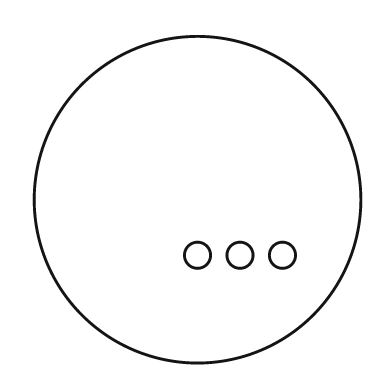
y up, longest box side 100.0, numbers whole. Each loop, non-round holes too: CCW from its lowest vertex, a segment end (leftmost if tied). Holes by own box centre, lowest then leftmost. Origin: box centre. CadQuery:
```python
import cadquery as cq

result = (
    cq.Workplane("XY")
    .moveTo(0.0, 0.0)
    .circle(50.0)
    .moveTo(0.0, -17.0)
    .circle(4.0)
    .moveTo(13.0, -17.0)
    .circle(4.0)
    .moveTo(26.0, -17.0)
    .circle(4.0)
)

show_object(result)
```